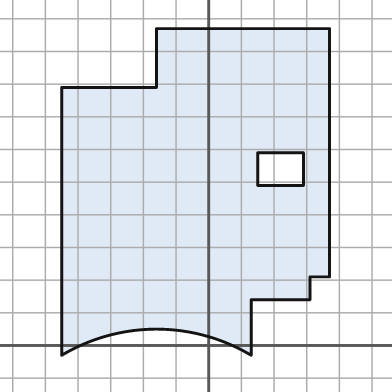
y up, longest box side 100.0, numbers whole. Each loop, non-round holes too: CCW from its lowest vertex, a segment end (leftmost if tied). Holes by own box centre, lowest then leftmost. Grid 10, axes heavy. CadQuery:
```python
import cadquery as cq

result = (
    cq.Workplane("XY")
    .moveTo(-45.0, -3.0)
    .threePointArc((-16.0, 5.0), (13.0, -3.0))
    .lineTo(13.0, 14.0)
    .lineTo(31.0, 14.0)
    .lineTo(31.0, 21.0)
    .lineTo(37.0, 21.0)
    .lineTo(37.0, 97.0)
    .lineTo(-16.0, 97.0)
    .lineTo(-16.0, 79.0)
    .lineTo(-45.0, 79.0)
    .close()
    .moveTo(15.0, 49.0)
    .lineTo(29.0, 49.0)
    .lineTo(29.0, 59.0)
    .lineTo(15.0, 59.0)
    .close()
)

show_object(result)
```